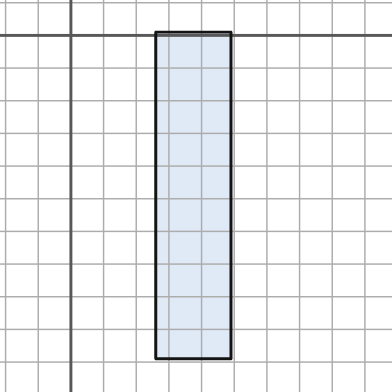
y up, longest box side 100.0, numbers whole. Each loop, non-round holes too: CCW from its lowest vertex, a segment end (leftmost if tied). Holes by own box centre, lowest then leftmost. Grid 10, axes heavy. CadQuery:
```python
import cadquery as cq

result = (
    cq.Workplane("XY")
    .moveTo(26.0, -99.0)
    .lineTo(49.0, -99.0)
    .lineTo(49.0, 1.0)
    .lineTo(26.0, 1.0)
    .close()
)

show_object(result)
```